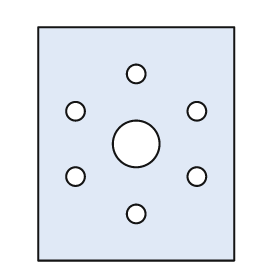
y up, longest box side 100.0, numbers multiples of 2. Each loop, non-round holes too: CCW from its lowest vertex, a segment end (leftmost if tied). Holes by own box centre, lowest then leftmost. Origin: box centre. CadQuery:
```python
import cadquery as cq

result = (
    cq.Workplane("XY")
    .moveTo(-42.0, -50.0)
    .lineTo(42.0, -50.0)
    .lineTo(42.0, 50.0)
    .lineTo(-42.0, 50.0)
    .close()
    .moveTo(0.0, -30.0)
    .circle(4.0)
    .moveTo(-26.0, -14.0)
    .circle(4.0)
    .moveTo(26.0, -14.0)
    .circle(4.0)
    .moveTo(0.0, 0.0)
    .circle(10.0)
    .moveTo(-26.0, 14.0)
    .circle(4.0)
    .moveTo(26.0, 14.0)
    .circle(4.0)
    .moveTo(0.0, 30.0)
    .circle(4.0)
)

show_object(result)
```